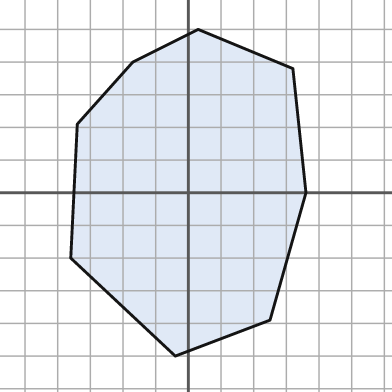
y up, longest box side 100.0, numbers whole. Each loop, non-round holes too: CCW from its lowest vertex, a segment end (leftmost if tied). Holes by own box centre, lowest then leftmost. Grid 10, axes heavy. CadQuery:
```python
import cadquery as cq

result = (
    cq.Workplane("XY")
    .moveTo(-4.0, -50.0)
    .lineTo(25.0, -39.0)
    .lineTo(36.0, 0.0)
    .lineTo(32.0, 38.0)
    .lineTo(3.0, 50.0)
    .lineTo(-17.0, 40.0)
    .lineTo(-34.0, 21.0)
    .lineTo(-36.0, -20.0)
    .close()
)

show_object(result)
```